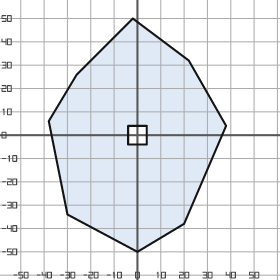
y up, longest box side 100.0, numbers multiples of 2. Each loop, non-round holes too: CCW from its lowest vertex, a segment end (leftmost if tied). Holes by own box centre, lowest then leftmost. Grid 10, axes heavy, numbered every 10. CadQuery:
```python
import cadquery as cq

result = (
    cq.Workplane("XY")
    .moveTo(0.0, -50.0)
    .lineTo(20.0, -38.0)
    .lineTo(38.0, 4.0)
    .lineTo(22.0, 32.0)
    .lineTo(-2.0, 50.0)
    .lineTo(-26.0, 26.0)
    .lineTo(-38.0, 6.0)
    .lineTo(-30.0, -34.0)
    .close()
    .moveTo(-4.0, -4.0)
    .lineTo(4.0, -4.0)
    .lineTo(4.0, 4.0)
    .lineTo(-4.0, 4.0)
    .close()
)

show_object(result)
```